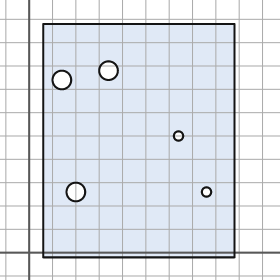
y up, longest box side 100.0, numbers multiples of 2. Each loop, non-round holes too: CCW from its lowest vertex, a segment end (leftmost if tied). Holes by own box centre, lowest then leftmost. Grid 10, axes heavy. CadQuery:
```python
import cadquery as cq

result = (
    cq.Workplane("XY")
    .moveTo(6.0, -2.0)
    .lineTo(88.0, -2.0)
    .lineTo(88.0, 98.0)
    .lineTo(6.0, 98.0)
    .close()
    .moveTo(20.0, 26.0)
    .circle(4.0)
    .moveTo(76.0, 26.0)
    .circle(2.0)
    .moveTo(64.0, 50.0)
    .circle(2.0)
    .moveTo(14.0, 74.0)
    .circle(4.0)
    .moveTo(34.0, 78.0)
    .circle(4.0)
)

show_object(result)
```